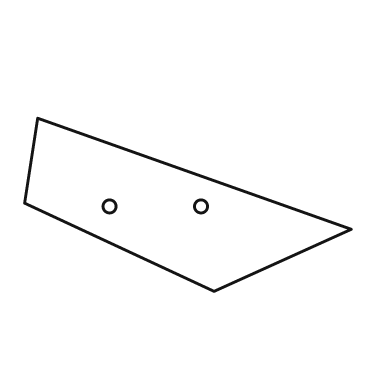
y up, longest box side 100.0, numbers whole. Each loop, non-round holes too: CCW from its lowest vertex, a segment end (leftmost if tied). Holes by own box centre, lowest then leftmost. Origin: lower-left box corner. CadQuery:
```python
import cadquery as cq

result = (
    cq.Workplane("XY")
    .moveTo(58.0, 0.0)
    .lineTo(100.0, 19.0)
    .lineTo(4.0, 53.0)
    .lineTo(0.0, 27.0)
    .close()
    .moveTo(26.0, 26.0)
    .circle(2.0)
    .moveTo(54.0, 26.0)
    .circle(2.0)
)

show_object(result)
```